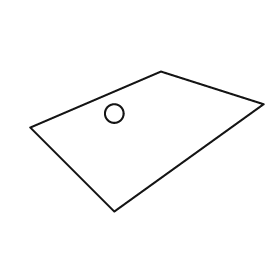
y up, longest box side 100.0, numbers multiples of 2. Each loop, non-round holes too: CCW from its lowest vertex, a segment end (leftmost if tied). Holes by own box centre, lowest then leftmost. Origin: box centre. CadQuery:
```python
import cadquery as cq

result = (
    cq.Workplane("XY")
    .moveTo(-14.0, -30.0)
    .lineTo(50.0, 16.0)
    .lineTo(6.0, 30.0)
    .lineTo(-50.0, 6.0)
    .close()
    .moveTo(-14.0, 12.0)
    .circle(4.0)
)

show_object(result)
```